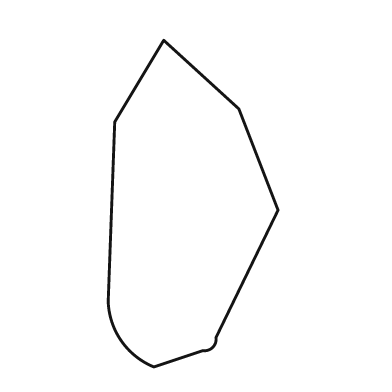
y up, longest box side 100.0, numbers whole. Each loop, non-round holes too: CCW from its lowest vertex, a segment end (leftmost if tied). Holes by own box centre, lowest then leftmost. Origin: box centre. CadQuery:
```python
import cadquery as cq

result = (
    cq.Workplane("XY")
    .moveTo(-12.0, -50.0)
    .lineTo(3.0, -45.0)
    .threePointArc((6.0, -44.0), (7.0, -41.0))
    .lineTo(26.0, -2.0)
    .lineTo(14.0, 29.0)
    .lineTo(-9.0, 50.0)
    .lineTo(-24.0, 25.0)
    .lineTo(-26.0, -30.0)
    .threePointArc((-22.0, -42.0), (-12.0, -50.0))
    .close()
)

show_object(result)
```